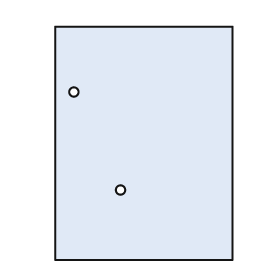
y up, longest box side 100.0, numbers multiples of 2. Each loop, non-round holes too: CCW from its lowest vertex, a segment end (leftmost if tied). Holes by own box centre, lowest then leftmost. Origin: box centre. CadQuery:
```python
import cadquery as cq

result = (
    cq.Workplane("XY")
    .moveTo(-38.0, -50.0)
    .lineTo(38.0, -50.0)
    .lineTo(38.0, 50.0)
    .lineTo(-38.0, 50.0)
    .close()
    .moveTo(-10.0, -20.0)
    .circle(2.0)
    .moveTo(-30.0, 22.0)
    .circle(2.0)
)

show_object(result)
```